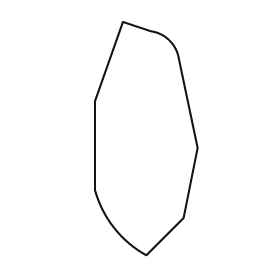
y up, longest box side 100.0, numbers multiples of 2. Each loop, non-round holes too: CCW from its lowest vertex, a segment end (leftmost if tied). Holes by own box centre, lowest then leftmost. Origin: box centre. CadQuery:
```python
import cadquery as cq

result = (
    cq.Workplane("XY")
    .moveTo(0.0, -50.0)
    .lineTo(16.0, -34.0)
    .lineTo(22.0, -4.0)
    .lineTo(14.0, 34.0)
    .threePointArc((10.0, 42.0), (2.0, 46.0))
    .lineTo(-10.0, 50.0)
    .lineTo(-22.0, 16.0)
    .lineTo(-22.0, -22.0)
    .threePointArc((-14.0, -38.0), (0.0, -50.0))
    .close()
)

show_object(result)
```